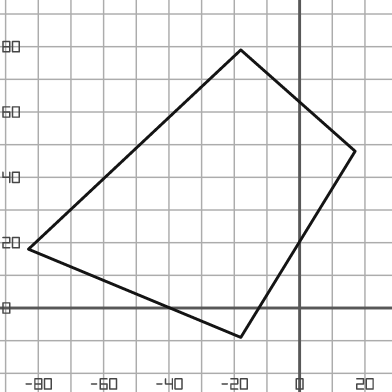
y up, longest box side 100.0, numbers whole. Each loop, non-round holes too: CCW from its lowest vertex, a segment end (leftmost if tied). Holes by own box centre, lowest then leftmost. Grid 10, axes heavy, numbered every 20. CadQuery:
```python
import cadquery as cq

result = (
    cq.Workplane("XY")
    .moveTo(-18.0, -9.0)
    .lineTo(17.0, 48.0)
    .lineTo(-18.0, 79.0)
    .lineTo(-83.0, 18.0)
    .close()
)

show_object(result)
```